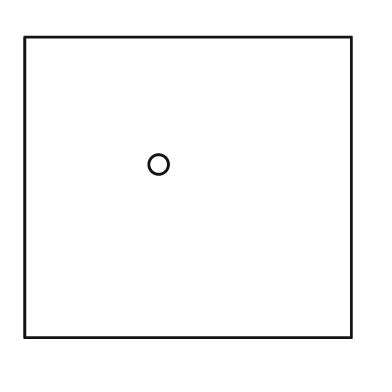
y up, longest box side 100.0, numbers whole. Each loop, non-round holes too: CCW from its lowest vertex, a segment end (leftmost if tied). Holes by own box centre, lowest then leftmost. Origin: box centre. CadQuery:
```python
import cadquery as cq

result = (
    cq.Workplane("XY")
    .moveTo(-50.0, -46.0)
    .lineTo(50.0, -46.0)
    .lineTo(50.0, 46.0)
    .lineTo(-50.0, 46.0)
    .close()
    .moveTo(-9.0, 7.0)
    .circle(3.0)
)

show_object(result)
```